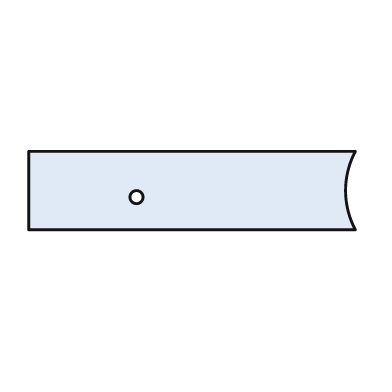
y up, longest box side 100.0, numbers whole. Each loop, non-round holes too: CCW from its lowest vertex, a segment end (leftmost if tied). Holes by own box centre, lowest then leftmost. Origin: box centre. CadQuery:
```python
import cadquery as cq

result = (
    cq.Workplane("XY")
    .moveTo(-50.0, -12.0)
    .lineTo(50.0, -12.0)
    .threePointArc((47.0, 0.0), (50.0, 12.0))
    .lineTo(-50.0, 12.0)
    .close()
    .moveTo(-17.0, -2.0)
    .circle(2.0)
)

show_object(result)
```